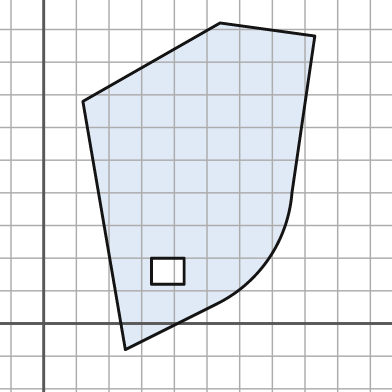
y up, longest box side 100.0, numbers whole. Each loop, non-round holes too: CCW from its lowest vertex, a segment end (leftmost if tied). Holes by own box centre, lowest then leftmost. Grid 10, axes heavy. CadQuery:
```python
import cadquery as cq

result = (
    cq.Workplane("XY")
    .moveTo(25.0, -8.0)
    .lineTo(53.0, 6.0)
    .threePointArc((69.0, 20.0), (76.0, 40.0))
    .lineTo(83.0, 88.0)
    .lineTo(54.0, 92.0)
    .lineTo(12.0, 68.0)
    .close()
    .moveTo(33.0, 12.0)
    .lineTo(43.0, 12.0)
    .lineTo(43.0, 20.0)
    .lineTo(33.0, 20.0)
    .close()
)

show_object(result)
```